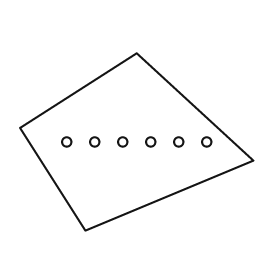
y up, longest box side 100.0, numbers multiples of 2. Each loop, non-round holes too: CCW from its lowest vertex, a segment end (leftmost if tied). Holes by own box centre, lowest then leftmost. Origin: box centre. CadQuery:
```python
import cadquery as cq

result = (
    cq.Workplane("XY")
    .moveTo(-22.0, -38.0)
    .lineTo(50.0, -8.0)
    .lineTo(0.0, 38.0)
    .lineTo(-50.0, 6.0)
    .close()
    .moveTo(-30.0, 0.0)
    .circle(2.0)
    .moveTo(-18.0, 0.0)
    .circle(2.0)
    .moveTo(-6.0, 0.0)
    .circle(2.0)
    .moveTo(6.0, 0.0)
    .circle(2.0)
    .moveTo(18.0, 0.0)
    .circle(2.0)
    .moveTo(30.0, 0.0)
    .circle(2.0)
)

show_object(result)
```